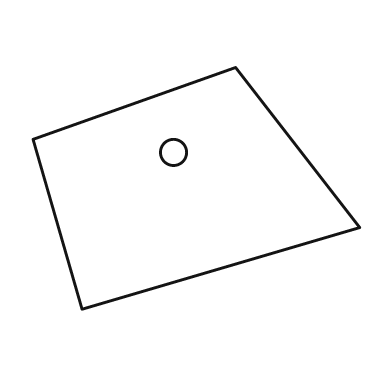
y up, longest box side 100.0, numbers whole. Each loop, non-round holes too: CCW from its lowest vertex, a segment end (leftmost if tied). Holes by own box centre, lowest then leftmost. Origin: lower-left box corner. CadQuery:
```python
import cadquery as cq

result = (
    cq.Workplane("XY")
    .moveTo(15.0, 0.0)
    .lineTo(100.0, 25.0)
    .lineTo(62.0, 74.0)
    .lineTo(0.0, 52.0)
    .close()
    .moveTo(43.0, 48.0)
    .circle(4.0)
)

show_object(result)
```